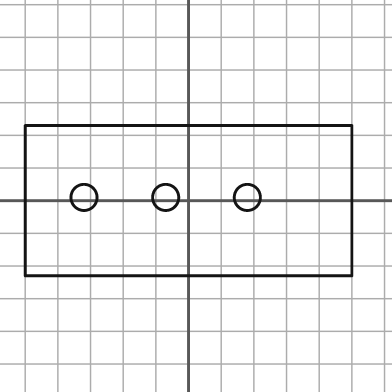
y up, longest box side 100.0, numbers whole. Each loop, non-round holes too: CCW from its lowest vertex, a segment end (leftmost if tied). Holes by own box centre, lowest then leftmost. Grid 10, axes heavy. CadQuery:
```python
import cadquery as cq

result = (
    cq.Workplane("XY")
    .moveTo(-50.0, -23.0)
    .lineTo(50.0, -23.0)
    .lineTo(50.0, 23.0)
    .lineTo(-50.0, 23.0)
    .close()
    .moveTo(-32.0, 1.0)
    .circle(4.0)
    .moveTo(-7.0, 1.0)
    .circle(4.0)
    .moveTo(18.0, 1.0)
    .circle(4.0)
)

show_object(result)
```